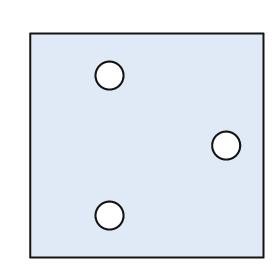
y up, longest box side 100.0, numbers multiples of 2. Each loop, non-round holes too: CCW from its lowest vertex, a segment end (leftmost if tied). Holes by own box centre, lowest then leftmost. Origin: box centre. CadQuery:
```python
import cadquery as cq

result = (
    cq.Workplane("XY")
    .moveTo(-50.0, -48.0)
    .lineTo(50.0, -48.0)
    .lineTo(50.0, 48.0)
    .lineTo(-50.0, 48.0)
    .close()
    .moveTo(-16.0, -30.0)
    .circle(6.0)
    .moveTo(34.0, 0.0)
    .circle(6.0)
    .moveTo(-16.0, 30.0)
    .circle(6.0)
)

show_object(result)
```